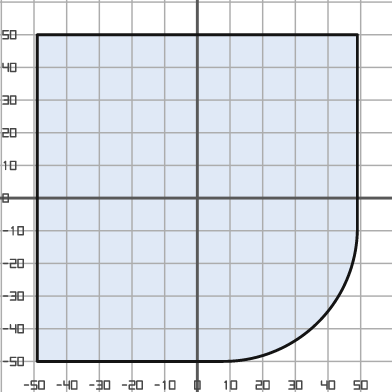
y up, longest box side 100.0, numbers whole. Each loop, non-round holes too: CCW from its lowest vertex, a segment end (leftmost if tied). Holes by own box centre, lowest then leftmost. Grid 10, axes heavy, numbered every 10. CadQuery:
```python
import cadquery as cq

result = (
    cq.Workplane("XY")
    .moveTo(-49.0, -50.0)
    .lineTo(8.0, -50.0)
    .threePointArc((37.0, -38.0), (49.0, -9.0))
    .lineTo(49.0, 50.0)
    .lineTo(-49.0, 50.0)
    .close()
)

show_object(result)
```